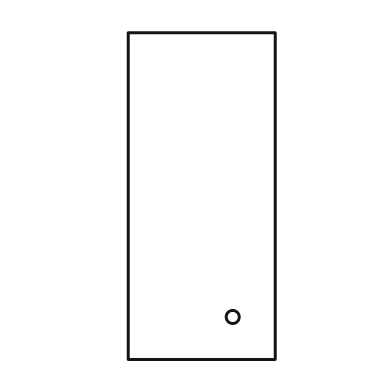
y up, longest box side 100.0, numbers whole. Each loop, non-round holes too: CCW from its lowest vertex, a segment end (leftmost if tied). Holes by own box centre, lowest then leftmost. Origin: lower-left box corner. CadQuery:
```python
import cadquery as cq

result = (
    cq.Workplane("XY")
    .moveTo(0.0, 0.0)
    .lineTo(45.0, 0.0)
    .lineTo(45.0, 100.0)
    .lineTo(0.0, 100.0)
    .close()
    .moveTo(32.0, 13.0)
    .circle(2.0)
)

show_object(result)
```